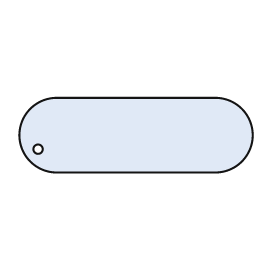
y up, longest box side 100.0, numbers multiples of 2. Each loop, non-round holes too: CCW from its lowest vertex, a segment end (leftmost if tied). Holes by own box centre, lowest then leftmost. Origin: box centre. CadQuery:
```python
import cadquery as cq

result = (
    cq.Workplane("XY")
    .moveTo(-34.0, -16.0)
    .lineTo(34.0, -16.0)
    .threePointArc((50.0, 0.0), (34.0, 16.0))
    .lineTo(-34.0, 16.0)
    .threePointArc((-50.0, 0.0), (-34.0, -16.0))
    .close()
    .moveTo(-42.0, -6.0)
    .circle(2.0)
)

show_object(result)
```